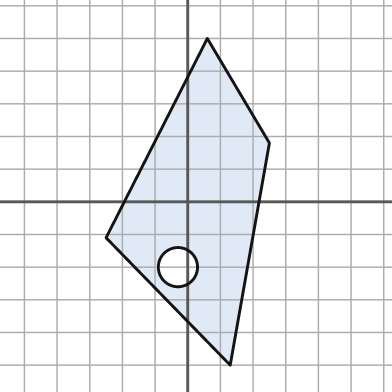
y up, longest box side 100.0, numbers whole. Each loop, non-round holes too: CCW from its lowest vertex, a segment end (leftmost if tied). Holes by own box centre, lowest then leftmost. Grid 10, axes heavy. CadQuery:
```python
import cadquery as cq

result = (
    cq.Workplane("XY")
    .moveTo(13.0, -50.0)
    .lineTo(25.0, 18.0)
    .lineTo(6.0, 50.0)
    .lineTo(-25.0, -11.0)
    .close()
    .moveTo(-3.0, -20.0)
    .circle(6.0)
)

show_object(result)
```